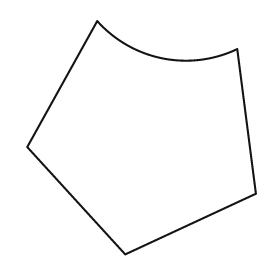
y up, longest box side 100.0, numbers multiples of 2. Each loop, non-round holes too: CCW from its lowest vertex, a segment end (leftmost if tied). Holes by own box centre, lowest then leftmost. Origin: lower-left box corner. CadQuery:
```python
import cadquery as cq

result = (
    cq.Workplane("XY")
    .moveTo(42.0, 0.0)
    .lineTo(98.0, 26.0)
    .lineTo(90.0, 88.0)
    .threePointArc((58.0, 84.0), (30.0, 100.0))
    .lineTo(0.0, 46.0)
    .close()
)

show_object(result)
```